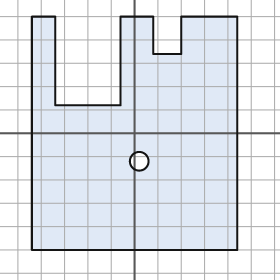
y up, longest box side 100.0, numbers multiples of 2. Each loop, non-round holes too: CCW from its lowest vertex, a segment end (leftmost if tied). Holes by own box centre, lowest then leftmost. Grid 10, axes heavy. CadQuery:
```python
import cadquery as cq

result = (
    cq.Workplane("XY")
    .moveTo(-44.0, -50.0)
    .lineTo(44.0, -50.0)
    .lineTo(44.0, 50.0)
    .lineTo(20.0, 50.0)
    .lineTo(20.0, 34.0)
    .lineTo(8.0, 34.0)
    .lineTo(8.0, 50.0)
    .lineTo(-6.0, 50.0)
    .lineTo(-6.0, 12.0)
    .lineTo(-34.0, 12.0)
    .lineTo(-34.0, 50.0)
    .lineTo(-44.0, 50.0)
    .close()
    .moveTo(2.0, -12.0)
    .circle(4.0)
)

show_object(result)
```